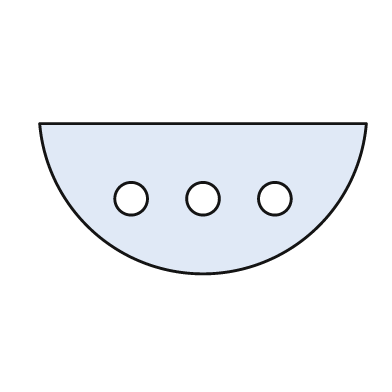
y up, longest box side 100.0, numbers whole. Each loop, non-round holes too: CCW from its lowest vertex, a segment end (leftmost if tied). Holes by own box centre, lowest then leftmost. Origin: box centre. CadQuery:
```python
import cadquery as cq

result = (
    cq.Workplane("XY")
    .moveTo(-50.0, 23.0)
    .threePointArc((0.0, -23.0), (50.0, 23.0))
    .close()
    .moveTo(-22.0, 0.0)
    .circle(5.0)
    .moveTo(0.0, 0.0)
    .circle(5.0)
    .moveTo(22.0, 0.0)
    .circle(5.0)
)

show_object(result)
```